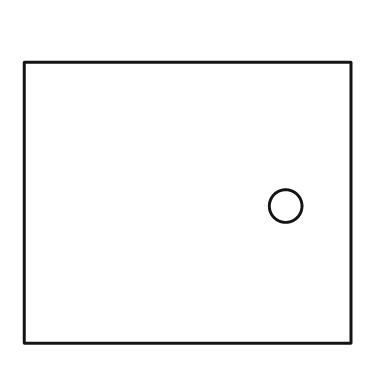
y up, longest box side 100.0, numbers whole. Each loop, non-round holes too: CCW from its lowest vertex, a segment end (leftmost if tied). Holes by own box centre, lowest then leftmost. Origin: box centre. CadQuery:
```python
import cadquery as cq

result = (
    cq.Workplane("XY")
    .moveTo(-50.0, -43.0)
    .lineTo(50.0, -43.0)
    .lineTo(50.0, 43.0)
    .lineTo(-50.0, 43.0)
    .close()
    .moveTo(30.0, -1.0)
    .circle(5.0)
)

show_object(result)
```